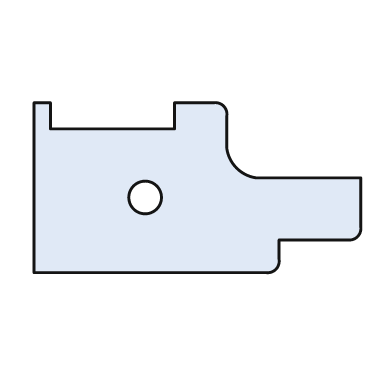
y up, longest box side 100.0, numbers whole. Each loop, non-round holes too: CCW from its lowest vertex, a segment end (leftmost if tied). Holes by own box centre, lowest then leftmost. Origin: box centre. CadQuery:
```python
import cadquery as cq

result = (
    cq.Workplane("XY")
    .moveTo(-50.0, -26.0)
    .lineTo(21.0, -26.0)
    .threePointArc((24.0, -25.0), (25.0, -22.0))
    .lineTo(25.0, -16.0)
    .lineTo(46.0, -16.0)
    .threePointArc((49.0, -15.0), (50.0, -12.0))
    .lineTo(50.0, 3.0)
    .lineTo(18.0, 3.0)
    .threePointArc((12.0, 6.0), (9.0, 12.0))
    .lineTo(9.0, 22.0)
    .threePointArc((8.0, 25.0), (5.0, 26.0))
    .lineTo(-7.0, 26.0)
    .lineTo(-7.0, 18.0)
    .lineTo(-45.0, 18.0)
    .lineTo(-45.0, 26.0)
    .lineTo(-50.0, 26.0)
    .close()
    .moveTo(-16.0, -3.0)
    .circle(5.0)
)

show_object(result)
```